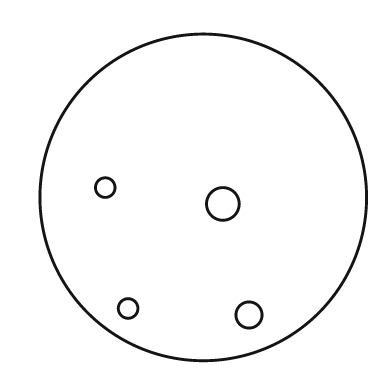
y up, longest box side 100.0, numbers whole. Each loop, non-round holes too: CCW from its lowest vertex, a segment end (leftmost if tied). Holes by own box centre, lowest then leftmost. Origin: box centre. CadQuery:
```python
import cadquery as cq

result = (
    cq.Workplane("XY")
    .moveTo(0.0, 0.0)
    .circle(50.0)
    .moveTo(14.0, -36.0)
    .circle(4.0)
    .moveTo(-23.0, -34.0)
    .circle(3.0)
    .moveTo(6.0, -2.0)
    .circle(5.0)
    .moveTo(-30.0, 3.0)
    .circle(3.0)
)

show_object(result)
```